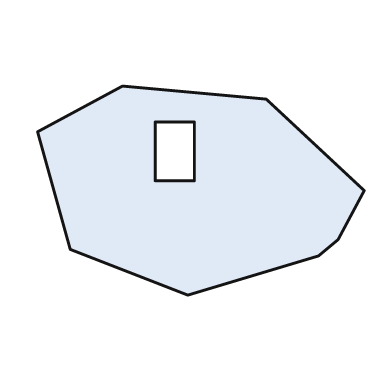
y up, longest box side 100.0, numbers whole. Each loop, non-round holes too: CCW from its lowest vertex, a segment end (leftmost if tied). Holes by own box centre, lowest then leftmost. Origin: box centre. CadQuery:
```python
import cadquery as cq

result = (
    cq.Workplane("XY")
    .moveTo(-4.0, -32.0)
    .lineTo(36.0, -20.0)
    .lineTo(42.0, -15.0)
    .lineTo(50.0, 0.0)
    .lineTo(20.0, 28.0)
    .lineTo(-24.0, 32.0)
    .lineTo(-50.0, 18.0)
    .lineTo(-40.0, -18.0)
    .close()
    .moveTo(-14.0, 3.0)
    .lineTo(-2.0, 3.0)
    .lineTo(-2.0, 21.0)
    .lineTo(-14.0, 21.0)
    .close()
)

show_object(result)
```